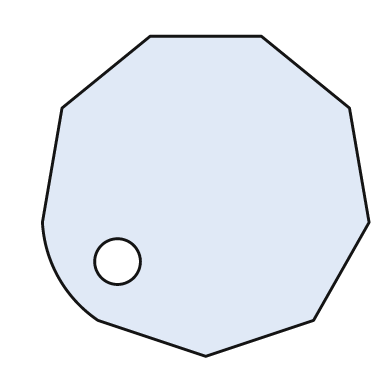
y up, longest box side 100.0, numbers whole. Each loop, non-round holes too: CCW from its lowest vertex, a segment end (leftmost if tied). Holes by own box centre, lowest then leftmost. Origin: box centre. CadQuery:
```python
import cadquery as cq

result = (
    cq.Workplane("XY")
    .moveTo(0.0, -49.0)
    .lineTo(33.0, -38.0)
    .lineTo(50.0, -8.0)
    .lineTo(44.0, 27.0)
    .lineTo(17.0, 49.0)
    .lineTo(-17.0, 49.0)
    .lineTo(-44.0, 27.0)
    .lineTo(-50.0, -8.0)
    .threePointArc((-45.0, -25.0), (-33.0, -38.0))
    .close()
    .moveTo(-27.0, -20.0)
    .circle(7.0)
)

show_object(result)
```